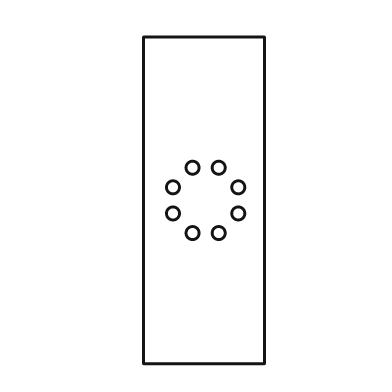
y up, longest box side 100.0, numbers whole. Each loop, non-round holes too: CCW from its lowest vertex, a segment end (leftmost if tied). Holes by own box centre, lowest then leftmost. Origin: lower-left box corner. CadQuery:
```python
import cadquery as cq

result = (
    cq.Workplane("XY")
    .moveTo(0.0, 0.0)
    .lineTo(37.0, 0.0)
    .lineTo(37.0, 100.0)
    .lineTo(0.0, 100.0)
    .close()
    .moveTo(15.0, 40.0)
    .circle(2.0)
    .moveTo(23.0, 40.0)
    .circle(2.0)
    .moveTo(9.0, 46.0)
    .circle(2.0)
    .moveTo(29.0, 46.0)
    .circle(2.0)
    .moveTo(9.0, 54.0)
    .circle(2.0)
    .moveTo(29.0, 54.0)
    .circle(2.0)
    .moveTo(15.0, 60.0)
    .circle(2.0)
    .moveTo(23.0, 60.0)
    .circle(2.0)
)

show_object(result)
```